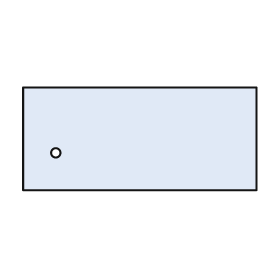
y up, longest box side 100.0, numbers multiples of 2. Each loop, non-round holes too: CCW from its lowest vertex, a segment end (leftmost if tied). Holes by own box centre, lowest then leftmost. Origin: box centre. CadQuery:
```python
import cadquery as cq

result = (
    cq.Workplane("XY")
    .moveTo(-50.0, -22.0)
    .lineTo(50.0, -22.0)
    .lineTo(50.0, 22.0)
    .lineTo(-50.0, 22.0)
    .close()
    .moveTo(-36.0, -6.0)
    .circle(2.0)
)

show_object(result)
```